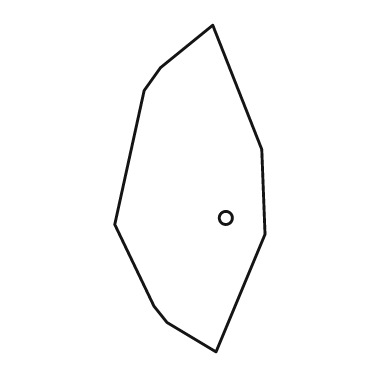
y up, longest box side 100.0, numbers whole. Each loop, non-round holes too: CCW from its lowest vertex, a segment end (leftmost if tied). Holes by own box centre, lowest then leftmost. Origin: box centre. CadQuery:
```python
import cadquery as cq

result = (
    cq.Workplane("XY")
    .moveTo(8.0, -50.0)
    .lineTo(23.0, -14.0)
    .lineTo(22.0, 12.0)
    .lineTo(7.0, 50.0)
    .lineTo(-9.0, 37.0)
    .lineTo(-14.0, 30.0)
    .lineTo(-23.0, -11.0)
    .lineTo(-11.0, -36.0)
    .lineTo(-7.0, -41.0)
    .close()
    .moveTo(11.0, -9.0)
    .circle(2.0)
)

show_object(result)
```